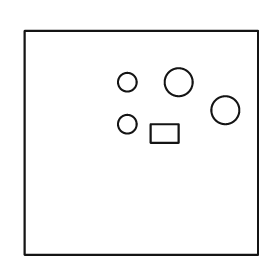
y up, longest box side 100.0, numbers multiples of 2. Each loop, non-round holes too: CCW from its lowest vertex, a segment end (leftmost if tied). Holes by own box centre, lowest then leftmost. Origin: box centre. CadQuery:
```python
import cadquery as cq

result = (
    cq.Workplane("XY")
    .moveTo(-50.0, -48.0)
    .lineTo(50.0, -48.0)
    .lineTo(50.0, 48.0)
    .lineTo(-50.0, 48.0)
    .close()
    .moveTo(4.0, 0.0)
    .lineTo(16.0, 0.0)
    .lineTo(16.0, 8.0)
    .lineTo(4.0, 8.0)
    .close()
    .moveTo(-6.0, 8.0)
    .circle(4.0)
    .moveTo(36.0, 14.0)
    .circle(6.0)
    .moveTo(-6.0, 26.0)
    .circle(4.0)
    .moveTo(16.0, 26.0)
    .circle(6.0)
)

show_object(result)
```